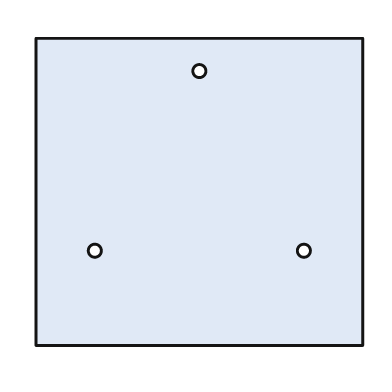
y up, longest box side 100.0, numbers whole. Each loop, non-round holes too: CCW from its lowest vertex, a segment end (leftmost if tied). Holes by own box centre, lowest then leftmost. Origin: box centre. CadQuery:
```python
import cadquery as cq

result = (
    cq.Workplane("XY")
    .moveTo(-50.0, -47.0)
    .lineTo(50.0, -47.0)
    .lineTo(50.0, 47.0)
    .lineTo(-50.0, 47.0)
    .close()
    .moveTo(-32.0, -18.0)
    .circle(2.0)
    .moveTo(32.0, -18.0)
    .circle(2.0)
    .moveTo(0.0, 37.0)
    .circle(2.0)
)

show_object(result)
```